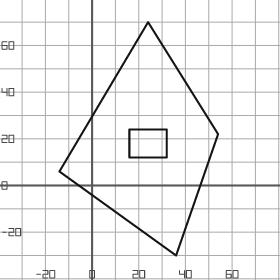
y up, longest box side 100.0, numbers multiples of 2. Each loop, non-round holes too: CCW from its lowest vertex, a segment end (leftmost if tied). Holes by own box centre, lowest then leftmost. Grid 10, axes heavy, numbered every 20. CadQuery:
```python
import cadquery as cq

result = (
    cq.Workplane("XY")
    .moveTo(36.0, -30.0)
    .lineTo(54.0, 22.0)
    .lineTo(24.0, 70.0)
    .lineTo(-14.0, 6.0)
    .close()
    .moveTo(16.0, 12.0)
    .lineTo(32.0, 12.0)
    .lineTo(32.0, 24.0)
    .lineTo(16.0, 24.0)
    .close()
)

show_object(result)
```